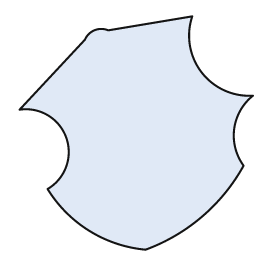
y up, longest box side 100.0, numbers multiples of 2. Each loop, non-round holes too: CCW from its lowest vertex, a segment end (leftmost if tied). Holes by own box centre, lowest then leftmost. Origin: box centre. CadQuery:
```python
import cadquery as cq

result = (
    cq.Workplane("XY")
    .moveTo(4.0, -50.0)
    .threePointArc((28.0, -36.0), (46.0, -14.0))
    .threePointArc((42.0, 2.0), (50.0, 16.0))
    .threePointArc((28.0, 26.0), (24.0, 50.0))
    .lineTo(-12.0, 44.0)
    .threePointArc((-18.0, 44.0), (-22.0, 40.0))
    .lineTo(-50.0, 10.0)
    .threePointArc((-30.0, -2.0), (-38.0, -24.0))
    .threePointArc((-20.0, -42.0), (4.0, -50.0))
    .close()
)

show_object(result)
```